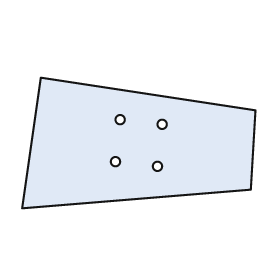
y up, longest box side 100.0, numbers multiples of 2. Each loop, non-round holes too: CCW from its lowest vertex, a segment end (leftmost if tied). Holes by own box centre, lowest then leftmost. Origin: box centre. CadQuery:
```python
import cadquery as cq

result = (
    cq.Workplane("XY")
    .moveTo(-50.0, -28.0)
    .lineTo(48.0, -20.0)
    .lineTo(50.0, 14.0)
    .lineTo(-42.0, 28.0)
    .close()
    .moveTo(8.0, -10.0)
    .circle(2.0)
    .moveTo(-10.0, -8.0)
    .circle(2.0)
    .moveTo(10.0, 8.0)
    .circle(2.0)
    .moveTo(-8.0, 10.0)
    .circle(2.0)
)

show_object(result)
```